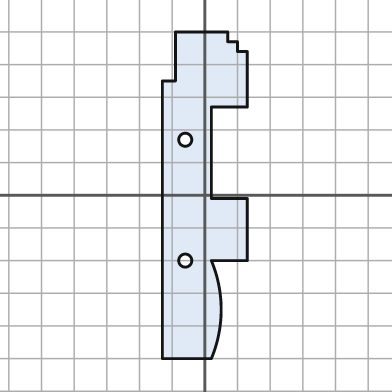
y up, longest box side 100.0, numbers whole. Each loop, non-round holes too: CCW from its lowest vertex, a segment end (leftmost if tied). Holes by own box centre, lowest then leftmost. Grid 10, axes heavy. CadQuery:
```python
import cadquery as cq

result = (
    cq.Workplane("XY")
    .moveTo(-13.0, -50.0)
    .lineTo(2.0, -50.0)
    .threePointArc((5.0, -35.0), (2.0, -20.0))
    .lineTo(13.0, -20.0)
    .lineTo(13.0, -1.0)
    .lineTo(2.0, -1.0)
    .lineTo(2.0, 27.0)
    .lineTo(13.0, 27.0)
    .lineTo(13.0, 44.0)
    .lineTo(10.0, 44.0)
    .lineTo(10.0, 47.0)
    .lineTo(7.0, 47.0)
    .lineTo(7.0, 50.0)
    .lineTo(-9.0, 50.0)
    .lineTo(-9.0, 35.0)
    .lineTo(-13.0, 35.0)
    .close()
    .moveTo(-6.0, -20.0)
    .circle(2.0)
    .moveTo(-6.0, 17.0)
    .circle(2.0)
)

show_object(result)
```